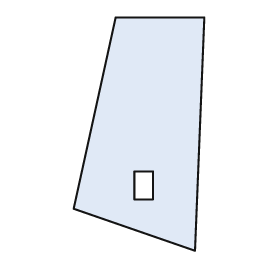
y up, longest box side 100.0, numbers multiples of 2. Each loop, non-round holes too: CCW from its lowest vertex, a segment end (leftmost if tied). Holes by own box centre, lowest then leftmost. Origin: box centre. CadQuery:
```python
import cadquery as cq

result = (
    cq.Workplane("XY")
    .moveTo(24.0, -50.0)
    .lineTo(28.0, 50.0)
    .lineTo(-10.0, 50.0)
    .lineTo(-28.0, -32.0)
    .close()
    .moveTo(-2.0, -28.0)
    .lineTo(6.0, -28.0)
    .lineTo(6.0, -16.0)
    .lineTo(-2.0, -16.0)
    .close()
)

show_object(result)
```